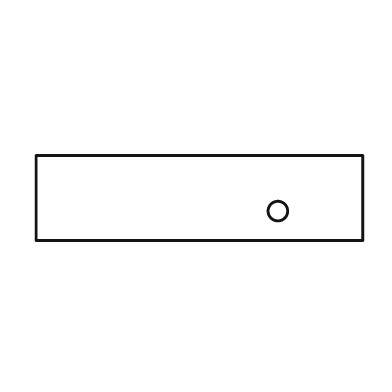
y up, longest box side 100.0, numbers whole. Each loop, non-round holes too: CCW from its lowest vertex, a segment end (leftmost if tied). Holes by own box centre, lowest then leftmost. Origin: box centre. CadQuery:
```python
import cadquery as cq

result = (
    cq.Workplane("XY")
    .moveTo(-50.0, -13.0)
    .lineTo(50.0, -13.0)
    .lineTo(50.0, 13.0)
    .lineTo(-50.0, 13.0)
    .close()
    .moveTo(24.0, -4.0)
    .circle(3.0)
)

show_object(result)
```